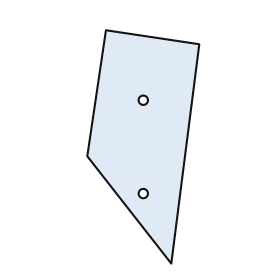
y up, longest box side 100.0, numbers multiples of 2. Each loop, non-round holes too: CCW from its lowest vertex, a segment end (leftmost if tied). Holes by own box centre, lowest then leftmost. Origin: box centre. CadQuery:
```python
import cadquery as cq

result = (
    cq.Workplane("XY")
    .moveTo(12.0, -50.0)
    .lineTo(24.0, 44.0)
    .lineTo(-16.0, 50.0)
    .lineTo(-24.0, -4.0)
    .close()
    .moveTo(0.0, -20.0)
    .circle(2.0)
    .moveTo(0.0, 20.0)
    .circle(2.0)
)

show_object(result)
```